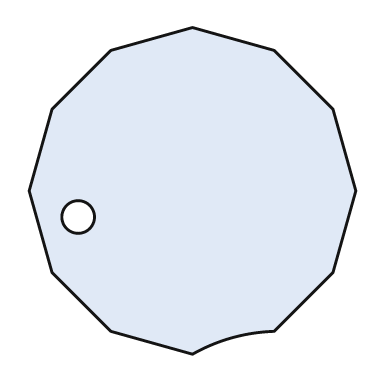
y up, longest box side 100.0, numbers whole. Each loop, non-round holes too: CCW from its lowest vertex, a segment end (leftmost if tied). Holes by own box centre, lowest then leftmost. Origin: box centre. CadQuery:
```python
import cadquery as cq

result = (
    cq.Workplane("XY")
    .moveTo(0.0, -50.0)
    .threePointArc((12.0, -45.0), (25.0, -43.0))
    .lineTo(43.0, -25.0)
    .lineTo(50.0, 0.0)
    .lineTo(43.0, 25.0)
    .lineTo(25.0, 43.0)
    .lineTo(0.0, 50.0)
    .lineTo(-25.0, 43.0)
    .lineTo(-43.0, 25.0)
    .lineTo(-50.0, 0.0)
    .lineTo(-43.0, -25.0)
    .lineTo(-25.0, -43.0)
    .close()
    .moveTo(-35.0, -8.0)
    .circle(5.0)
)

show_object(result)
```